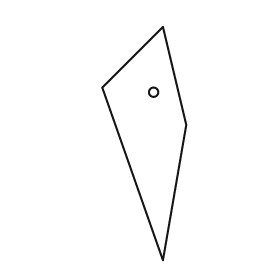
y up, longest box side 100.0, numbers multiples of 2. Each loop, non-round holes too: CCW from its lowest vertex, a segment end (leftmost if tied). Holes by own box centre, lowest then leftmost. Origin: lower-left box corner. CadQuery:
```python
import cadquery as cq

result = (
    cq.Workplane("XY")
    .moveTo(26.0, 0.0)
    .lineTo(36.0, 58.0)
    .lineTo(26.0, 100.0)
    .lineTo(0.0, 74.0)
    .close()
    .moveTo(22.0, 72.0)
    .circle(2.0)
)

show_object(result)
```